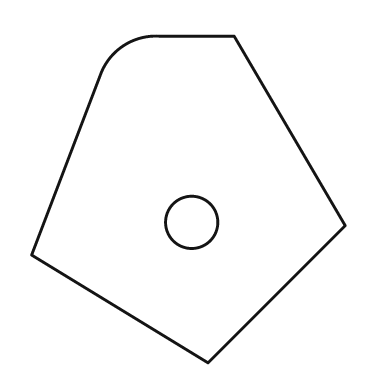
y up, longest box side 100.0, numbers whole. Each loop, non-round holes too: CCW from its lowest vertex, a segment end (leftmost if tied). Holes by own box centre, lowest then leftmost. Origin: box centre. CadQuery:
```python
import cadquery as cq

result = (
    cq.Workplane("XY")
    .moveTo(6.0, -50.0)
    .lineTo(48.0, -8.0)
    .lineTo(14.0, 50.0)
    .lineTo(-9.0, 50.0)
    .threePointArc((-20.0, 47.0), (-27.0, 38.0))
    .lineTo(-48.0, -17.0)
    .close()
    .moveTo(1.0, -7.0)
    .circle(8.0)
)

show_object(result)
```